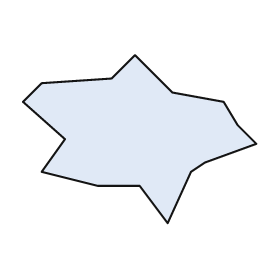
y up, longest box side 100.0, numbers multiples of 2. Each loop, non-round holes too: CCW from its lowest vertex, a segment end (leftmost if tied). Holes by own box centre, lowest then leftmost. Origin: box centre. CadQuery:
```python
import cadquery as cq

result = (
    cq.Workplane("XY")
    .moveTo(12.0, -36.0)
    .lineTo(22.0, -14.0)
    .lineTo(28.0, -10.0)
    .lineTo(50.0, -2.0)
    .lineTo(42.0, 6.0)
    .lineTo(36.0, 16.0)
    .lineTo(14.0, 20.0)
    .lineTo(-2.0, 36.0)
    .lineTo(-12.0, 26.0)
    .lineTo(-42.0, 24.0)
    .lineTo(-50.0, 16.0)
    .lineTo(-32.0, 0.0)
    .lineTo(-42.0, -14.0)
    .lineTo(-18.0, -20.0)
    .lineTo(0.0, -20.0)
    .close()
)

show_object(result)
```